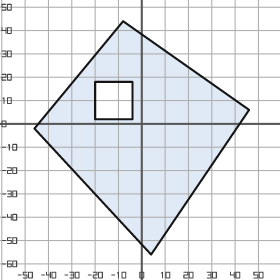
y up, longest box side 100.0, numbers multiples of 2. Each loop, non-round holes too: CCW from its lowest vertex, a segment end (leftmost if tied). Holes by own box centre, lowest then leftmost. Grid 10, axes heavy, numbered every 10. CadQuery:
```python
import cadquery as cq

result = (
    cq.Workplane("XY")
    .moveTo(4.0, -56.0)
    .lineTo(46.0, 6.0)
    .lineTo(-8.0, 44.0)
    .lineTo(-46.0, -2.0)
    .close()
    .moveTo(-20.0, 2.0)
    .lineTo(-4.0, 2.0)
    .lineTo(-4.0, 18.0)
    .lineTo(-20.0, 18.0)
    .close()
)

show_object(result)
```